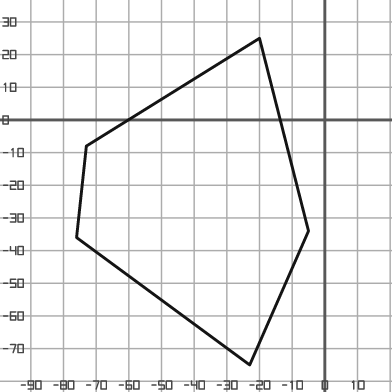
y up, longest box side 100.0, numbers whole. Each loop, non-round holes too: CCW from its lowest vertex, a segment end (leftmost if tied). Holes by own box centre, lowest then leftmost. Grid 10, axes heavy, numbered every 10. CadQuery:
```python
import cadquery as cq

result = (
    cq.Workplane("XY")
    .moveTo(-23.0, -75.0)
    .lineTo(-5.0, -34.0)
    .lineTo(-20.0, 25.0)
    .lineTo(-73.0, -8.0)
    .lineTo(-76.0, -36.0)
    .close()
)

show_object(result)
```